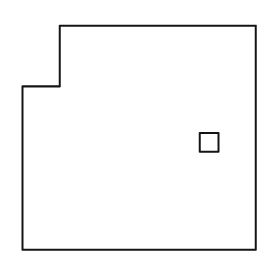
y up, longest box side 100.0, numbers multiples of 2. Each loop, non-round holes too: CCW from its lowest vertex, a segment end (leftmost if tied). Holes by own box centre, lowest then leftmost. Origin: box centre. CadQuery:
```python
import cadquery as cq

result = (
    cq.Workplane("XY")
    .moveTo(-50.0, -48.0)
    .lineTo(50.0, -48.0)
    .lineTo(50.0, 48.0)
    .lineTo(-34.0, 48.0)
    .lineTo(-34.0, 22.0)
    .lineTo(-50.0, 22.0)
    .close()
    .moveTo(26.0, -6.0)
    .lineTo(34.0, -6.0)
    .lineTo(34.0, 2.0)
    .lineTo(26.0, 2.0)
    .close()
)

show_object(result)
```